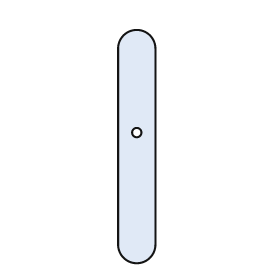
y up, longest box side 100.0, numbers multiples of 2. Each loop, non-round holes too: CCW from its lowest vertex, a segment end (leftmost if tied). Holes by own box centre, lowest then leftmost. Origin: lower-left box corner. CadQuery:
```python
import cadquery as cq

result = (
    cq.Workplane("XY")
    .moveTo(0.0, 8.0)
    .threePointArc((8.0, 0.0), (16.0, 8.0))
    .lineTo(16.0, 92.0)
    .threePointArc((8.0, 100.0), (0.0, 92.0))
    .close()
    .moveTo(8.0, 56.0)
    .circle(2.0)
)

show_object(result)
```